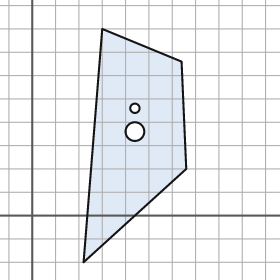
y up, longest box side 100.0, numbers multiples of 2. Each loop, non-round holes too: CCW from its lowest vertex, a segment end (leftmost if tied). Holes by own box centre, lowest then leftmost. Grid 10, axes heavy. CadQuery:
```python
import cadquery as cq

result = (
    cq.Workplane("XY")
    .moveTo(22.0, -20.0)
    .lineTo(66.0, 20.0)
    .lineTo(64.0, 66.0)
    .lineTo(30.0, 80.0)
    .close()
    .moveTo(44.0, 36.0)
    .circle(4.0)
    .moveTo(44.0, 46.0)
    .circle(2.0)
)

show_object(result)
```